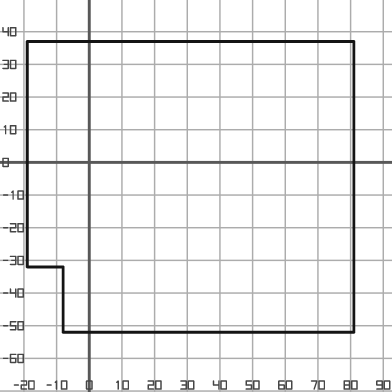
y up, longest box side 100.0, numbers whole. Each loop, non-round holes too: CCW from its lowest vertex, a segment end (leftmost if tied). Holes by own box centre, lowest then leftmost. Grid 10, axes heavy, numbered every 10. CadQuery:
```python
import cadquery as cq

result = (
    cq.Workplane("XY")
    .moveTo(-8.0, -52.0)
    .lineTo(81.0, -52.0)
    .lineTo(81.0, 37.0)
    .lineTo(-19.0, 37.0)
    .lineTo(-19.0, -32.0)
    .lineTo(-8.0, -32.0)
    .close()
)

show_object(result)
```